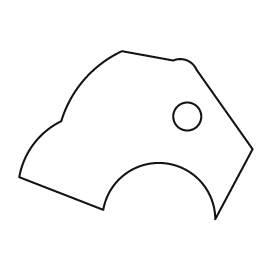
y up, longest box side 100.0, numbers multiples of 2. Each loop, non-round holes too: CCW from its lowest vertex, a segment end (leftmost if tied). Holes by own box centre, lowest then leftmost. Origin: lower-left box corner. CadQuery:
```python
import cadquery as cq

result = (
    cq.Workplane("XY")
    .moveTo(84.0, 0.0)
    .lineTo(100.0, 30.0)
    .lineTo(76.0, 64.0)
    .threePointArc((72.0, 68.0), (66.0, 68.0))
    .lineTo(44.0, 72.0)
    .threePointArc((28.0, 60.0), (18.0, 42.0))
    .threePointArc((6.0, 32.0), (0.0, 18.0))
    .lineTo(36.0, 4.0)
    .threePointArc((62.0, 24.0), (84.0, 0.0))
    .close()
    .moveTo(72.0, 44.0)
    .circle(6.0)
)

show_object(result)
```